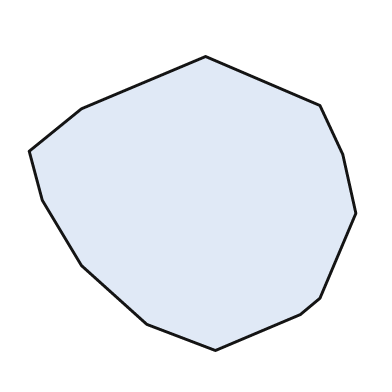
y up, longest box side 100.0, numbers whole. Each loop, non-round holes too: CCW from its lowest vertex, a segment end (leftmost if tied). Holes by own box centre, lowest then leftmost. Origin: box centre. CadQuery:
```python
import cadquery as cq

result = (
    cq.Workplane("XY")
    .moveTo(7.0, -45.0)
    .lineTo(33.0, -34.0)
    .lineTo(39.0, -29.0)
    .lineTo(50.0, -3.0)
    .lineTo(46.0, 15.0)
    .lineTo(39.0, 30.0)
    .lineTo(4.0, 45.0)
    .lineTo(-34.0, 29.0)
    .lineTo(-50.0, 16.0)
    .lineTo(-46.0, 1.0)
    .lineTo(-34.0, -19.0)
    .lineTo(-14.0, -37.0)
    .close()
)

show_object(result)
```